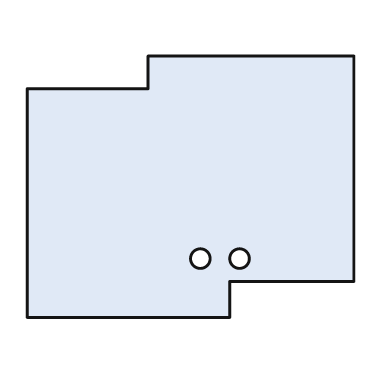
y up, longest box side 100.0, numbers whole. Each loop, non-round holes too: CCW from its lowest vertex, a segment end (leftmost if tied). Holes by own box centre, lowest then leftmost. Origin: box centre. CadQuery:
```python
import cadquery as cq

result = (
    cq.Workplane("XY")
    .moveTo(-50.0, -40.0)
    .lineTo(12.0, -40.0)
    .lineTo(12.0, -29.0)
    .lineTo(50.0, -29.0)
    .lineTo(50.0, 40.0)
    .lineTo(-13.0, 40.0)
    .lineTo(-13.0, 30.0)
    .lineTo(-50.0, 30.0)
    .close()
    .moveTo(3.0, -22.0)
    .circle(3.0)
    .moveTo(15.0, -22.0)
    .circle(3.0)
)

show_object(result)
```